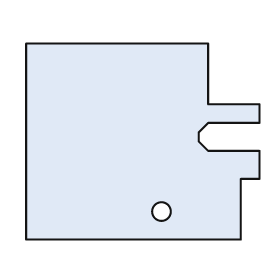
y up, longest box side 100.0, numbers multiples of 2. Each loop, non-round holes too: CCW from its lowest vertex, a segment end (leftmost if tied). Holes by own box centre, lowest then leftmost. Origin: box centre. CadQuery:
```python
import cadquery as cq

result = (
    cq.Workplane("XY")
    .moveTo(-50.0, -42.0)
    .lineTo(42.0, -42.0)
    .lineTo(42.0, -16.0)
    .lineTo(50.0, -16.0)
    .lineTo(50.0, -4.0)
    .lineTo(28.0, -4.0)
    .lineTo(24.0, 0.0)
    .lineTo(24.0, 4.0)
    .lineTo(28.0, 8.0)
    .lineTo(50.0, 8.0)
    .lineTo(50.0, 16.0)
    .lineTo(28.0, 16.0)
    .lineTo(28.0, 42.0)
    .lineTo(-50.0, 42.0)
    .close()
    .moveTo(8.0, -30.0)
    .circle(4.0)
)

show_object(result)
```